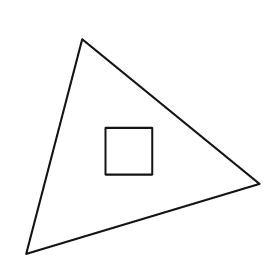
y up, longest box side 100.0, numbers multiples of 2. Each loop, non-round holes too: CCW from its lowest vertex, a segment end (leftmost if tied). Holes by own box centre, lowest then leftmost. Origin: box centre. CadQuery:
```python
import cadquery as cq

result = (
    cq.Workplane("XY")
    .moveTo(-50.0, -46.0)
    .lineTo(50.0, -16.0)
    .lineTo(-26.0, 46.0)
    .close()
    .moveTo(-16.0, -12.0)
    .lineTo(4.0, -12.0)
    .lineTo(4.0, 8.0)
    .lineTo(-16.0, 8.0)
    .close()
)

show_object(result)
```